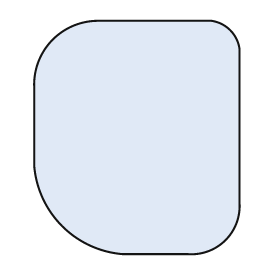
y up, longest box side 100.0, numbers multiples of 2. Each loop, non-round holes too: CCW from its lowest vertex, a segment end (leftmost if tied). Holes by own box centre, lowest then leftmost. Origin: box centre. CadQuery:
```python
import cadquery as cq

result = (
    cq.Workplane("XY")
    .moveTo(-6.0, -50.0)
    .lineTo(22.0, -50.0)
    .threePointArc((38.0, -44.0), (44.0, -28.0))
    .lineTo(44.0, 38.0)
    .threePointArc((40.0, 46.0), (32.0, 50.0))
    .lineTo(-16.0, 50.0)
    .threePointArc((-36.0, 42.0), (-44.0, 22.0))
    .lineTo(-44.0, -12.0)
    .threePointArc((-32.0, -38.0), (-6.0, -50.0))
    .close()
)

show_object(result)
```